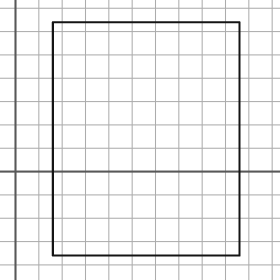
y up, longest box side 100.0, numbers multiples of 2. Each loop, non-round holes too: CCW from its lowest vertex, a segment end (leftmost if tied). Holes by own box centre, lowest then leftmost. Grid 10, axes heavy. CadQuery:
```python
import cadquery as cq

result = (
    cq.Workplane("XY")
    .moveTo(16.0, -36.0)
    .lineTo(96.0, -36.0)
    .lineTo(96.0, 64.0)
    .lineTo(16.0, 64.0)
    .close()
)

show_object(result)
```